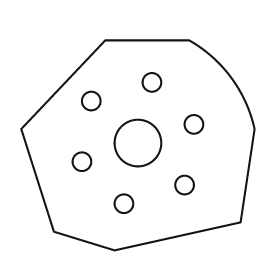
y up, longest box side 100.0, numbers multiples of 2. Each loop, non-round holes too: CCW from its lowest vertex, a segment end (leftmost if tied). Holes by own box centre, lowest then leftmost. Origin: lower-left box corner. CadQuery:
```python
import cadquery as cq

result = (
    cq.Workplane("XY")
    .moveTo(40.0, 0.0)
    .lineTo(94.0, 12.0)
    .lineTo(100.0, 52.0)
    .threePointArc((90.0, 74.0), (72.0, 90.0))
    .lineTo(36.0, 90.0)
    .lineTo(0.0, 52.0)
    .lineTo(14.0, 8.0)
    .close()
    .moveTo(44.0, 20.0)
    .circle(4.0)
    .moveTo(70.0, 28.0)
    .circle(4.0)
    .moveTo(26.0, 38.0)
    .circle(4.0)
    .moveTo(50.0, 46.0)
    .circle(10.0)
    .moveTo(74.0, 54.0)
    .circle(4.0)
    .moveTo(30.0, 64.0)
    .circle(4.0)
    .moveTo(56.0, 72.0)
    .circle(4.0)
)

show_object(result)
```